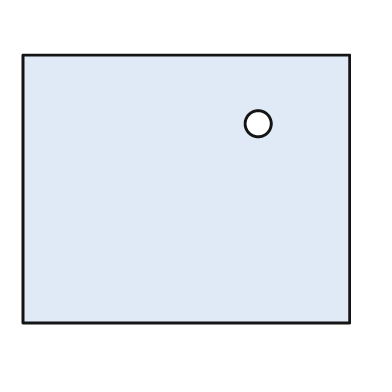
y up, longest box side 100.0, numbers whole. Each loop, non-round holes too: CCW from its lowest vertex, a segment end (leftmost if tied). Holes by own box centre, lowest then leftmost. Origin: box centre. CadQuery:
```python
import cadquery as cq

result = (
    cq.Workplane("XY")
    .moveTo(-50.0, -41.0)
    .lineTo(50.0, -41.0)
    .lineTo(50.0, 41.0)
    .lineTo(-50.0, 41.0)
    .close()
    .moveTo(22.0, 20.0)
    .circle(4.0)
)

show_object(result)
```